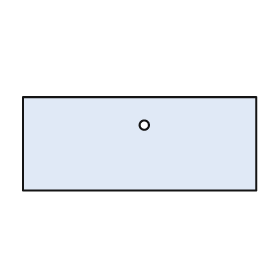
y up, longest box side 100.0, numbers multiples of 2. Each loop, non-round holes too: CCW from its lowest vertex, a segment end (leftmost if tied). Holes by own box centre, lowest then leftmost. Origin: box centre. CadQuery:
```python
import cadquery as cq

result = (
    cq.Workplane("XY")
    .moveTo(-50.0, -20.0)
    .lineTo(50.0, -20.0)
    .lineTo(50.0, 20.0)
    .lineTo(-50.0, 20.0)
    .close()
    .moveTo(2.0, 8.0)
    .circle(2.0)
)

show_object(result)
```